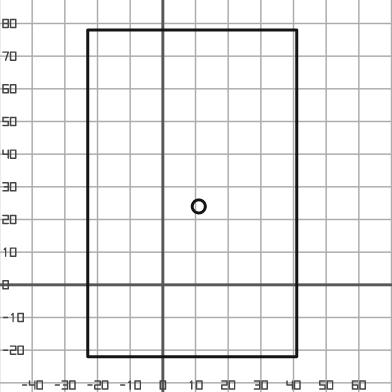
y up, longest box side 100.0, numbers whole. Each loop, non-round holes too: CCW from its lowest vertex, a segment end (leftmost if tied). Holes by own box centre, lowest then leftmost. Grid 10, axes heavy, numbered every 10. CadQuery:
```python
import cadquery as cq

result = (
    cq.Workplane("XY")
    .moveTo(-23.0, -22.0)
    .lineTo(41.0, -22.0)
    .lineTo(41.0, 78.0)
    .lineTo(-23.0, 78.0)
    .close()
    .moveTo(11.0, 24.0)
    .circle(2.0)
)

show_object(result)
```